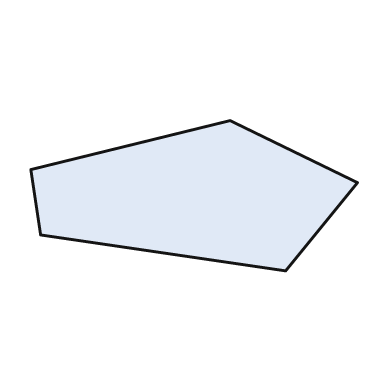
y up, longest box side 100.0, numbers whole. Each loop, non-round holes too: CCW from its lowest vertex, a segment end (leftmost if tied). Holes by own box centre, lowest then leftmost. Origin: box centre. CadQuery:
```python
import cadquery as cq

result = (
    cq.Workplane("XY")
    .moveTo(28.0, -23.0)
    .lineTo(50.0, 4.0)
    .lineTo(11.0, 23.0)
    .lineTo(-50.0, 8.0)
    .lineTo(-47.0, -12.0)
    .close()
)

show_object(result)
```